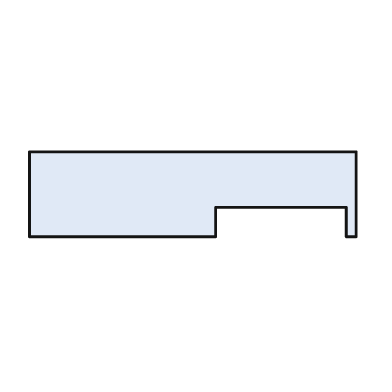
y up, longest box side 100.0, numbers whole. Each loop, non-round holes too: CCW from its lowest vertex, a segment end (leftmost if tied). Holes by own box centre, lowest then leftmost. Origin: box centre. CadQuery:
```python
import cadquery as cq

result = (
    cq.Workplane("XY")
    .moveTo(-50.0, -13.0)
    .lineTo(7.0, -13.0)
    .lineTo(7.0, -4.0)
    .lineTo(47.0, -4.0)
    .lineTo(47.0, -13.0)
    .lineTo(50.0, -13.0)
    .lineTo(50.0, 13.0)
    .lineTo(-50.0, 13.0)
    .close()
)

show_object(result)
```